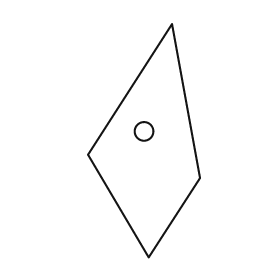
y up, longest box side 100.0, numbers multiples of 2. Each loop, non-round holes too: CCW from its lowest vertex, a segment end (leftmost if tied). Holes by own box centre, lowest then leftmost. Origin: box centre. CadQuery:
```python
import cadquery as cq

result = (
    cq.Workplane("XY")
    .moveTo(2.0, -50.0)
    .lineTo(24.0, -16.0)
    .lineTo(12.0, 50.0)
    .lineTo(-24.0, -6.0)
    .close()
    .moveTo(0.0, 4.0)
    .circle(4.0)
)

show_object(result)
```